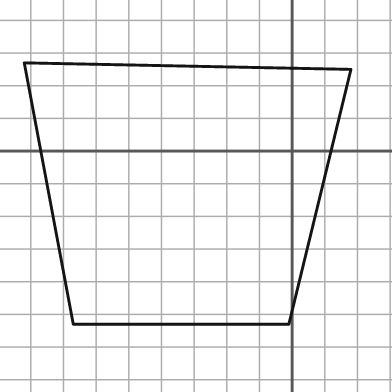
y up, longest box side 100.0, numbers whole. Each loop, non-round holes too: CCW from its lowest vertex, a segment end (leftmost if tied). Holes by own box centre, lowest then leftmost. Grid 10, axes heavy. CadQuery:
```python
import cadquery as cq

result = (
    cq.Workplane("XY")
    .moveTo(-67.0, -53.0)
    .lineTo(-1.0, -53.0)
    .lineTo(18.0, 25.0)
    .lineTo(-82.0, 27.0)
    .close()
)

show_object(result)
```